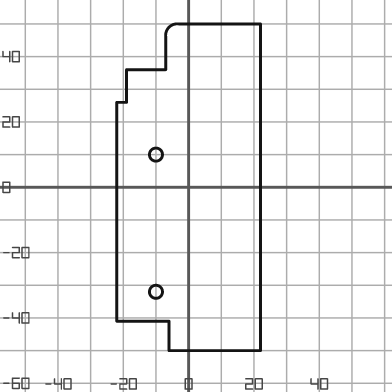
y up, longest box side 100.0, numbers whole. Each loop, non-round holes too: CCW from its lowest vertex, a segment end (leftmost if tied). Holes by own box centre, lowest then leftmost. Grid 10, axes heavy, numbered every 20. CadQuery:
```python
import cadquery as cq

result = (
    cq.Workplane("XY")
    .moveTo(-6.0, -50.0)
    .lineTo(22.0, -50.0)
    .lineTo(22.0, 50.0)
    .lineTo(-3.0, 50.0)
    .threePointArc((-6.0, 49.0), (-7.0, 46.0))
    .lineTo(-7.0, 36.0)
    .lineTo(-19.0, 36.0)
    .lineTo(-19.0, 26.0)
    .lineTo(-22.0, 26.0)
    .lineTo(-22.0, -41.0)
    .lineTo(-6.0, -41.0)
    .close()
    .moveTo(-10.0, -32.0)
    .circle(2.0)
    .moveTo(-10.0, 10.0)
    .circle(2.0)
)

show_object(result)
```